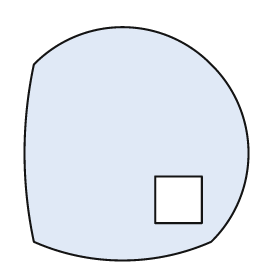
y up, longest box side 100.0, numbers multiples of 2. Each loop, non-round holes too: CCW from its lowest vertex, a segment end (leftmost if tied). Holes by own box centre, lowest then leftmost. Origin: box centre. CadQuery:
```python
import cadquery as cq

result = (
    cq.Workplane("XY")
    .moveTo(-44.0, -42.0)
    .threePointArc((-6.0, -50.0), (32.0, -42.0))
    .threePointArc((48.0, -4.0), (32.0, 34.0))
    .threePointArc((-6.0, 50.0), (-44.0, 34.0))
    .threePointArc((-48.0, -4.0), (-44.0, -42.0))
    .close()
    .moveTo(8.0, -34.0)
    .lineTo(28.0, -34.0)
    .lineTo(28.0, -14.0)
    .lineTo(8.0, -14.0)
    .close()
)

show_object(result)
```